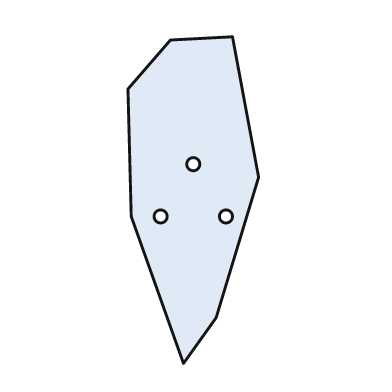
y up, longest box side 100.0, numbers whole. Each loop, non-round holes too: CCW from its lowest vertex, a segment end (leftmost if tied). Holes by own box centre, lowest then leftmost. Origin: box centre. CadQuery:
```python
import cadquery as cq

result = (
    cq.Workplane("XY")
    .moveTo(-3.0, -50.0)
    .lineTo(7.0, -36.0)
    .lineTo(20.0, 7.0)
    .lineTo(12.0, 50.0)
    .lineTo(-7.0, 49.0)
    .lineTo(-20.0, 34.0)
    .lineTo(-19.0, -5.0)
    .close()
    .moveTo(-10.0, -5.0)
    .circle(2.0)
    .moveTo(10.0, -5.0)
    .circle(2.0)
    .moveTo(0.0, 11.0)
    .circle(2.0)
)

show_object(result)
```